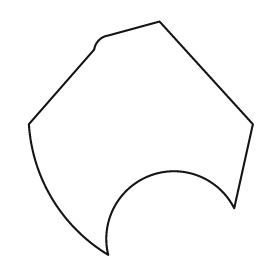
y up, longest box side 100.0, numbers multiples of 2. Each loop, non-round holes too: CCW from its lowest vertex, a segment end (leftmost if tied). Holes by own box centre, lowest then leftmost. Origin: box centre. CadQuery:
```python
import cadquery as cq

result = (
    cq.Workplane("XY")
    .moveTo(-14.0, -50.0)
    .threePointArc((4.0, -16.0), (40.0, -30.0))
    .lineTo(48.0, 6.0)
    .lineTo(8.0, 50.0)
    .lineTo(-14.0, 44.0)
    .threePointArc((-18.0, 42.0), (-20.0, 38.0))
    .lineTo(-48.0, 6.0)
    .threePointArc((-38.0, -26.0), (-14.0, -50.0))
    .close()
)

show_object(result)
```